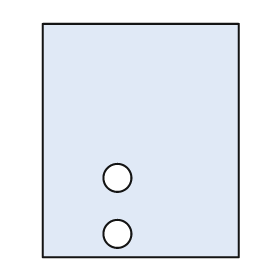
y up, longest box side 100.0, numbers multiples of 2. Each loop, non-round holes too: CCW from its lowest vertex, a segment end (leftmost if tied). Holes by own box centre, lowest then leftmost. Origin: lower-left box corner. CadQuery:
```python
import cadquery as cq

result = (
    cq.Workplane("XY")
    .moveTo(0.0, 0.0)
    .lineTo(84.0, 0.0)
    .lineTo(84.0, 100.0)
    .lineTo(0.0, 100.0)
    .close()
    .moveTo(32.0, 10.0)
    .circle(6.0)
    .moveTo(32.0, 34.0)
    .circle(6.0)
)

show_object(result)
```